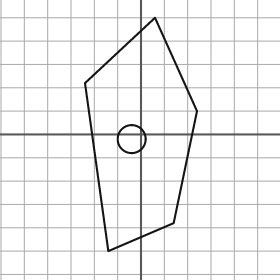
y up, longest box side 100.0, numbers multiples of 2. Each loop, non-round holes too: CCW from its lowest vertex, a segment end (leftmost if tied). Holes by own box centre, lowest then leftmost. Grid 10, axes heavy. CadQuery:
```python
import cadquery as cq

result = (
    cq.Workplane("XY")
    .moveTo(-14.0, -50.0)
    .lineTo(14.0, -38.0)
    .lineTo(24.0, 10.0)
    .lineTo(6.0, 50.0)
    .lineTo(-24.0, 22.0)
    .close()
    .moveTo(-4.0, -2.0)
    .circle(6.0)
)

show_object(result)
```